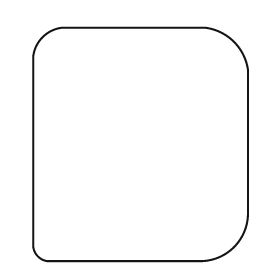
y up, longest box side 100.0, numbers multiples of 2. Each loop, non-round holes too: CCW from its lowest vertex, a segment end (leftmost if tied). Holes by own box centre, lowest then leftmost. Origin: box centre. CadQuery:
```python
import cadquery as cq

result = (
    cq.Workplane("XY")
    .moveTo(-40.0, -50.0)
    .lineTo(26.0, -50.0)
    .threePointArc((40.0, -44.0), (46.0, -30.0))
    .lineTo(46.0, 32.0)
    .threePointArc((40.0, 44.0), (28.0, 50.0))
    .lineTo(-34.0, 50.0)
    .threePointArc((-42.0, 46.0), (-46.0, 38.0))
    .lineTo(-46.0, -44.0)
    .threePointArc((-44.0, -48.0), (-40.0, -50.0))
    .close()
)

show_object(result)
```